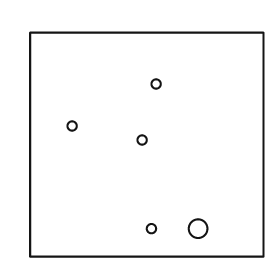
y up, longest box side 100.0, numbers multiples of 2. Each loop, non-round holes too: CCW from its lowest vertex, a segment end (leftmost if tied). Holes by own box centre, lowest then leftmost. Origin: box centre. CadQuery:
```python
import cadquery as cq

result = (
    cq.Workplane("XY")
    .moveTo(-50.0, -48.0)
    .lineTo(50.0, -48.0)
    .lineTo(50.0, 48.0)
    .lineTo(-50.0, 48.0)
    .close()
    .moveTo(2.0, -36.0)
    .circle(2.0)
    .moveTo(22.0, -36.0)
    .circle(4.0)
    .moveTo(-2.0, 2.0)
    .circle(2.0)
    .moveTo(-32.0, 8.0)
    .circle(2.0)
    .moveTo(4.0, 26.0)
    .circle(2.0)
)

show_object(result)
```